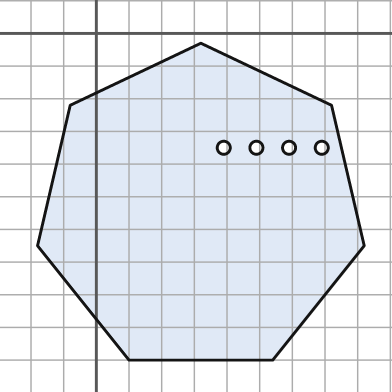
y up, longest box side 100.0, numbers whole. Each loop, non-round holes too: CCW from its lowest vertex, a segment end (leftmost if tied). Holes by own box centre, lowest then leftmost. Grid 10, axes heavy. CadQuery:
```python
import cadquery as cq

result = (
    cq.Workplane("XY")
    .moveTo(10.0, -100.0)
    .lineTo(54.0, -100.0)
    .lineTo(82.0, -65.0)
    .lineTo(72.0, -22.0)
    .lineTo(32.0, -3.0)
    .lineTo(-8.0, -22.0)
    .lineTo(-18.0, -65.0)
    .close()
    .moveTo(39.0, -35.0)
    .circle(2.0)
    .moveTo(49.0, -35.0)
    .circle(2.0)
    .moveTo(59.0, -35.0)
    .circle(2.0)
    .moveTo(69.0, -35.0)
    .circle(2.0)
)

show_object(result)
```